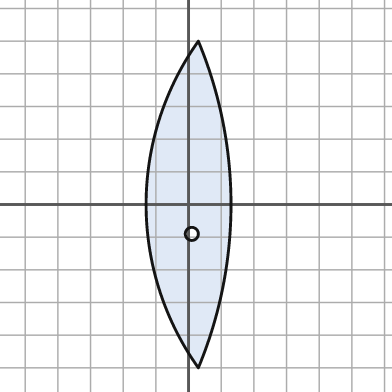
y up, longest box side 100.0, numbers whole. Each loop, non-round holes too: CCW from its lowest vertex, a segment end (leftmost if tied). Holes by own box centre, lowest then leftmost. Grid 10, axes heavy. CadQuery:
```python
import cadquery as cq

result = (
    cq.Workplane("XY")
    .moveTo(3.0, -50.0)
    .threePointArc((13.0, 0.0), (3.0, 50.0))
    .threePointArc((-13.0, 0.0), (3.0, -50.0))
    .close()
    .moveTo(1.0, -9.0)
    .circle(2.0)
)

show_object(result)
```